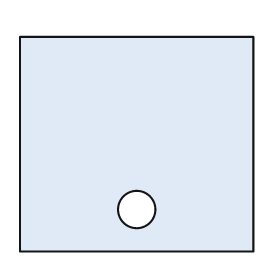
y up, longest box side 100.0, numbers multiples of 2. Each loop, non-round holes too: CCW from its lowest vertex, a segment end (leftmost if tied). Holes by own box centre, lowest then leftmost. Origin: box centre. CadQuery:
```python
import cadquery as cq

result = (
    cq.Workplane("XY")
    .moveTo(-50.0, -46.0)
    .lineTo(50.0, -46.0)
    .lineTo(50.0, 46.0)
    .lineTo(-50.0, 46.0)
    .close()
    .moveTo(0.0, -28.0)
    .circle(8.0)
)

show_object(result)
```